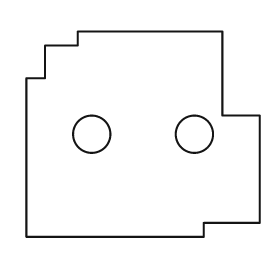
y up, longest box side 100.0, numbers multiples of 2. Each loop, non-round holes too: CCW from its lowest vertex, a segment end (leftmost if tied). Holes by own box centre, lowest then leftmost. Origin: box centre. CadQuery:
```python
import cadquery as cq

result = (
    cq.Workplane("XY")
    .moveTo(-50.0, -44.0)
    .lineTo(26.0, -44.0)
    .lineTo(26.0, -38.0)
    .lineTo(50.0, -38.0)
    .lineTo(50.0, 8.0)
    .lineTo(34.0, 8.0)
    .lineTo(34.0, 44.0)
    .lineTo(-28.0, 44.0)
    .lineTo(-28.0, 38.0)
    .lineTo(-42.0, 38.0)
    .lineTo(-42.0, 24.0)
    .lineTo(-50.0, 24.0)
    .close()
    .moveTo(-22.0, 0.0)
    .circle(8.0)
    .moveTo(22.0, 0.0)
    .circle(8.0)
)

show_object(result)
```